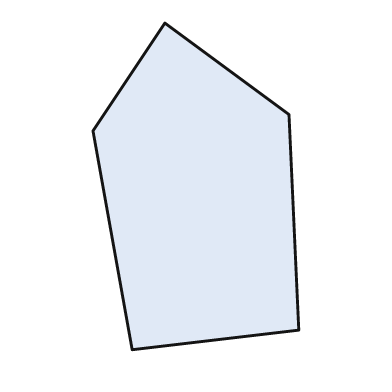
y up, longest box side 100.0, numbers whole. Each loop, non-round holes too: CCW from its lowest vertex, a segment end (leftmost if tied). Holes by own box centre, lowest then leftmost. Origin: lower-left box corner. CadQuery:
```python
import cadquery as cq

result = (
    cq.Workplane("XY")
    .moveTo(12.0, 0.0)
    .lineTo(63.0, 6.0)
    .lineTo(60.0, 72.0)
    .lineTo(22.0, 100.0)
    .lineTo(0.0, 67.0)
    .close()
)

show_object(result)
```